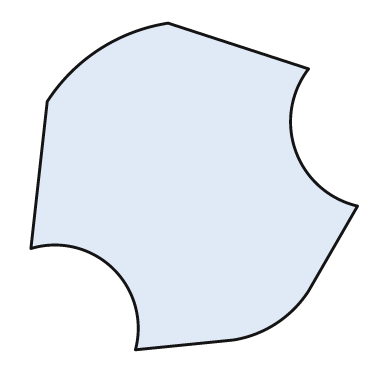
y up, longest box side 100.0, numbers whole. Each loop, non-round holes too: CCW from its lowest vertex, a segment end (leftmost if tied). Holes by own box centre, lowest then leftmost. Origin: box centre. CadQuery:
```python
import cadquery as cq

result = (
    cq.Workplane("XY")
    .moveTo(-18.0, -50.0)
    .lineTo(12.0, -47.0)
    .threePointArc((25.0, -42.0), (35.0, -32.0))
    .lineTo(50.0, -6.0)
    .threePointArc((31.0, 11.0), (35.0, 36.0))
    .lineTo(-8.0, 50.0)
    .threePointArc((-29.0, 42.0), (-45.0, 26.0))
    .lineTo(-50.0, -19.0)
    .threePointArc((-25.0, -25.0), (-18.0, -50.0))
    .close()
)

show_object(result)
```